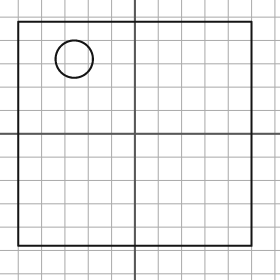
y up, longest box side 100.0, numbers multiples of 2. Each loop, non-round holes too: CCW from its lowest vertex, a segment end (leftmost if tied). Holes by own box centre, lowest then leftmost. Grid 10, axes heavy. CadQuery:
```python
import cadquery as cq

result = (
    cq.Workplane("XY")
    .moveTo(-50.0, -48.0)
    .lineTo(50.0, -48.0)
    .lineTo(50.0, 48.0)
    .lineTo(-50.0, 48.0)
    .close()
    .moveTo(-26.0, 32.0)
    .circle(8.0)
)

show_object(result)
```